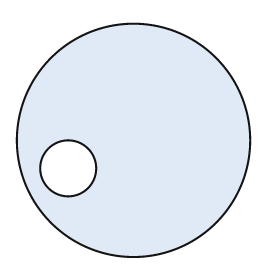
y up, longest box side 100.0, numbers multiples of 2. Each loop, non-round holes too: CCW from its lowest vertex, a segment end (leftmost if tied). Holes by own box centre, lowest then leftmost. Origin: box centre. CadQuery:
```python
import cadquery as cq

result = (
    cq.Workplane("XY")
    .moveTo(0.0, 0.0)
    .circle(50.0)
    .moveTo(-28.0, -12.0)
    .circle(12.0)
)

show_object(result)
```